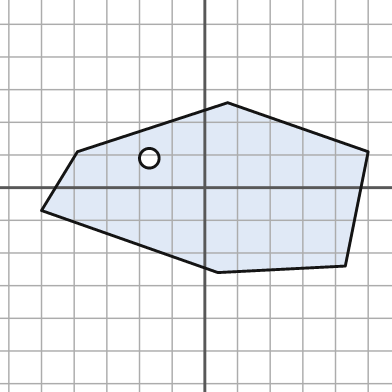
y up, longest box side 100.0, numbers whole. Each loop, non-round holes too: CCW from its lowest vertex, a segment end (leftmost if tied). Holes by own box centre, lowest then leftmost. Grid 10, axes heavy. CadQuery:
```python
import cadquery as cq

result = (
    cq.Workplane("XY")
    .moveTo(4.0, -26.0)
    .lineTo(43.0, -24.0)
    .lineTo(50.0, 11.0)
    .lineTo(7.0, 26.0)
    .lineTo(-39.0, 11.0)
    .lineTo(-50.0, -7.0)
    .close()
    .moveTo(-17.0, 9.0)
    .circle(3.0)
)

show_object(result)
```